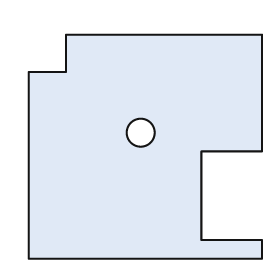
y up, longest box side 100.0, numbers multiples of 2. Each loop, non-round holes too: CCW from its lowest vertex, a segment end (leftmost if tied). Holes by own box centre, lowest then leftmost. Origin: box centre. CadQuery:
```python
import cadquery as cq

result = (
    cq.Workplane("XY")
    .moveTo(-50.0, -48.0)
    .lineTo(50.0, -48.0)
    .lineTo(50.0, -40.0)
    .lineTo(24.0, -40.0)
    .lineTo(24.0, -2.0)
    .lineTo(50.0, -2.0)
    .lineTo(50.0, 48.0)
    .lineTo(-34.0, 48.0)
    .lineTo(-34.0, 32.0)
    .lineTo(-50.0, 32.0)
    .close()
    .moveTo(-2.0, 6.0)
    .circle(6.0)
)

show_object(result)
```